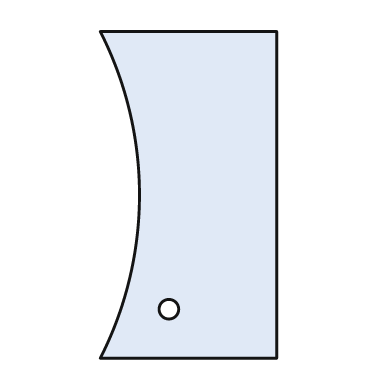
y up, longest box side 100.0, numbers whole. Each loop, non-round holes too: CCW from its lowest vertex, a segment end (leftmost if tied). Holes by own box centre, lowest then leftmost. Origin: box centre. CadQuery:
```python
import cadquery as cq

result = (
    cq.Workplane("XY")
    .moveTo(-27.0, -50.0)
    .lineTo(27.0, -50.0)
    .lineTo(27.0, 50.0)
    .lineTo(-27.0, 50.0)
    .threePointArc((-15.0, 0.0), (-27.0, -50.0))
    .close()
    .moveTo(-6.0, -35.0)
    .circle(3.0)
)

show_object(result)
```